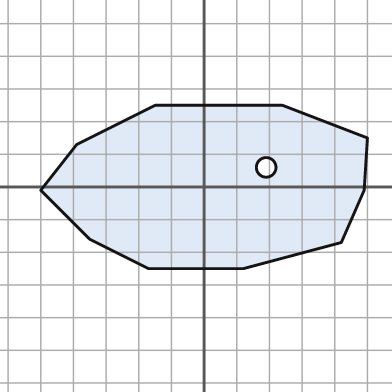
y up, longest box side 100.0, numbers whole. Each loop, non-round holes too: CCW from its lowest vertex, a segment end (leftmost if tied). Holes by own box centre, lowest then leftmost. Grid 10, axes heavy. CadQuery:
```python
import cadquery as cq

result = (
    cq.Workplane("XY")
    .moveTo(-17.0, -25.0)
    .lineTo(12.0, -25.0)
    .lineTo(42.0, -17.0)
    .lineTo(49.0, -1.0)
    .lineTo(50.0, 15.0)
    .lineTo(24.0, 25.0)
    .lineTo(-15.0, 25.0)
    .lineTo(-39.0, 13.0)
    .lineTo(-50.0, -1.0)
    .lineTo(-35.0, -16.0)
    .close()
    .moveTo(19.0, 6.0)
    .circle(3.0)
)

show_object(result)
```